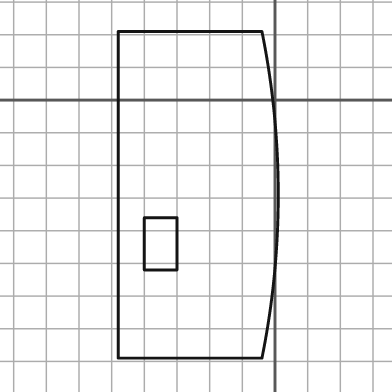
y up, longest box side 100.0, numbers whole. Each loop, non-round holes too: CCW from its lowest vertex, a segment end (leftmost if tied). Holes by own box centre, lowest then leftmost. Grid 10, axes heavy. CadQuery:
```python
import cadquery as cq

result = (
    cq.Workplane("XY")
    .moveTo(-48.0, -79.0)
    .lineTo(-4.0, -79.0)
    .threePointArc((1.0, -29.0), (-4.0, 21.0))
    .lineTo(-48.0, 21.0)
    .close()
    .moveTo(-40.0, -52.0)
    .lineTo(-30.0, -52.0)
    .lineTo(-30.0, -36.0)
    .lineTo(-40.0, -36.0)
    .close()
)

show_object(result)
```